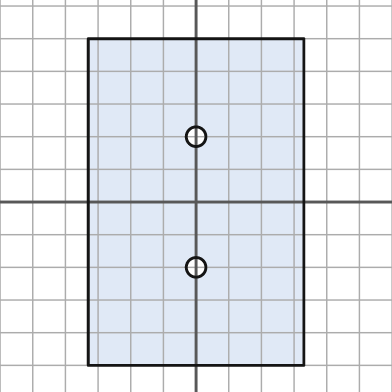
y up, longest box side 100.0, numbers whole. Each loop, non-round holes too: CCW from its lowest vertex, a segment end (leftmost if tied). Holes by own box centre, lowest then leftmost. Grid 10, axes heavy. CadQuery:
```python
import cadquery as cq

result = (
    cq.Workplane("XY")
    .moveTo(-33.0, -50.0)
    .lineTo(33.0, -50.0)
    .lineTo(33.0, 50.0)
    .lineTo(-33.0, 50.0)
    .close()
    .moveTo(0.0, -20.0)
    .circle(3.0)
    .moveTo(0.0, 20.0)
    .circle(3.0)
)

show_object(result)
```